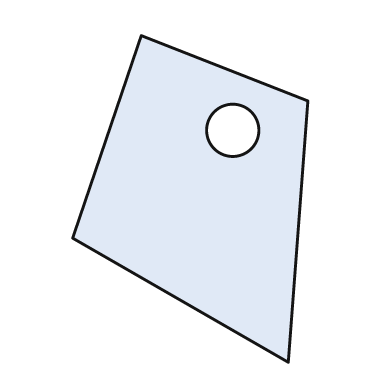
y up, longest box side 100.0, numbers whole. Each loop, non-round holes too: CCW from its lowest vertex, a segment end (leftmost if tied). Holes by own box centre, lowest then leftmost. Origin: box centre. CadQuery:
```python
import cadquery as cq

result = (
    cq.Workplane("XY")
    .moveTo(30.0, -50.0)
    .lineTo(36.0, 30.0)
    .lineTo(-15.0, 50.0)
    .lineTo(-36.0, -12.0)
    .close()
    .moveTo(13.0, 21.0)
    .circle(8.0)
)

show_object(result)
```